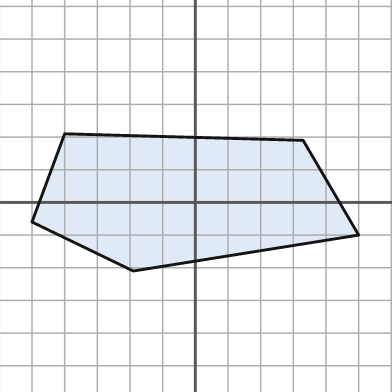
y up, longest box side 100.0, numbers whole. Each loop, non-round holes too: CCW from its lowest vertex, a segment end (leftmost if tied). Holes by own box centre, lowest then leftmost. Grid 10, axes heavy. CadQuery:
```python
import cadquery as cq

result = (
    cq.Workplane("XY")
    .moveTo(-19.0, -21.0)
    .lineTo(50.0, -10.0)
    .lineTo(33.0, 19.0)
    .lineTo(-40.0, 21.0)
    .lineTo(-50.0, -6.0)
    .close()
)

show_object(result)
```